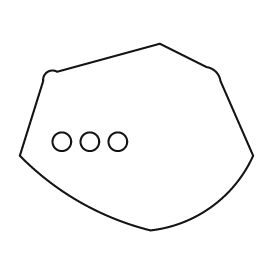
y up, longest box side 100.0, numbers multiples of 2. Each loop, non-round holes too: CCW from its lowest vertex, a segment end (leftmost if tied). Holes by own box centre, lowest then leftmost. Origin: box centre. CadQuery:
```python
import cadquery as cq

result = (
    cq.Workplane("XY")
    .moveTo(6.0, -40.0)
    .threePointArc((32.0, -30.0), (50.0, -8.0))
    .lineTo(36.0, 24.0)
    .threePointArc((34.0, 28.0), (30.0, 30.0))
    .lineTo(10.0, 40.0)
    .lineTo(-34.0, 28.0)
    .threePointArc((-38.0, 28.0), (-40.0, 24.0))
    .lineTo(-50.0, -8.0)
    .threePointArc((-24.0, -28.0), (6.0, -40.0))
    .close()
    .moveTo(-32.0, -2.0)
    .circle(4.0)
    .moveTo(-20.0, -2.0)
    .circle(4.0)
    .moveTo(-8.0, -2.0)
    .circle(4.0)
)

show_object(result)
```